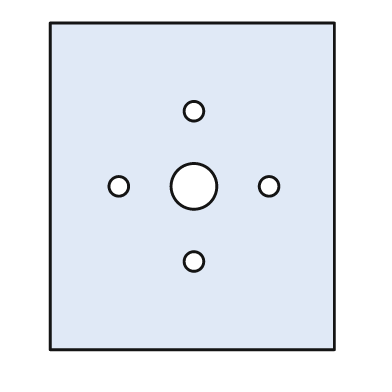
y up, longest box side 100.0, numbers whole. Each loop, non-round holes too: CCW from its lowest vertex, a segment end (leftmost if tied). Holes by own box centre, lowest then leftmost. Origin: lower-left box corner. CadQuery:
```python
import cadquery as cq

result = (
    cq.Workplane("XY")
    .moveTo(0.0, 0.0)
    .lineTo(87.0, 0.0)
    .lineTo(87.0, 100.0)
    .lineTo(0.0, 100.0)
    .close()
    .moveTo(44.0, 27.0)
    .circle(3.0)
    .moveTo(21.0, 50.0)
    .circle(3.0)
    .moveTo(44.0, 50.0)
    .circle(7.0)
    .moveTo(67.0, 50.0)
    .circle(3.0)
    .moveTo(44.0, 73.0)
    .circle(3.0)
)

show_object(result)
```